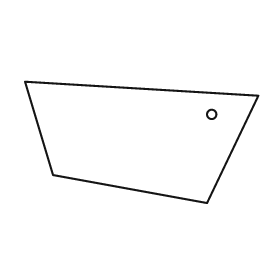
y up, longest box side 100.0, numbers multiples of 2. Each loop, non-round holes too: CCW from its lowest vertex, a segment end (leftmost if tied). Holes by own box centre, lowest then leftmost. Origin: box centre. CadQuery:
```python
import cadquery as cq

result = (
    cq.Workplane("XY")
    .moveTo(28.0, -26.0)
    .lineTo(50.0, 20.0)
    .lineTo(-50.0, 26.0)
    .lineTo(-38.0, -14.0)
    .close()
    .moveTo(30.0, 12.0)
    .circle(2.0)
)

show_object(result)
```